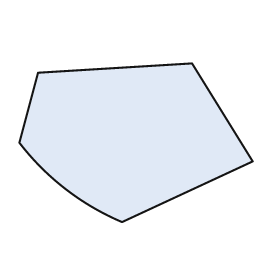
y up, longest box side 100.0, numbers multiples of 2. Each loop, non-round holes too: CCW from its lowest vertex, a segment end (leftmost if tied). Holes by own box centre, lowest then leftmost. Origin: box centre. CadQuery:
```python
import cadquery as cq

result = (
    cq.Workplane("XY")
    .moveTo(-6.0, -34.0)
    .lineTo(50.0, -8.0)
    .lineTo(24.0, 34.0)
    .lineTo(-42.0, 30.0)
    .lineTo(-50.0, 0.0)
    .threePointArc((-30.0, -20.0), (-6.0, -34.0))
    .close()
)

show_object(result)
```